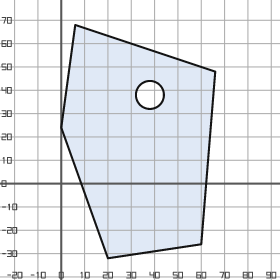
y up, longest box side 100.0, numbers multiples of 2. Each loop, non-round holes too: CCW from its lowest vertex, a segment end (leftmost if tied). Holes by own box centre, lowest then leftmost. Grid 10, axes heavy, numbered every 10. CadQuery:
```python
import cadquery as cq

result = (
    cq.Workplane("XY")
    .moveTo(20.0, -32.0)
    .lineTo(60.0, -26.0)
    .lineTo(66.0, 48.0)
    .lineTo(6.0, 68.0)
    .lineTo(0.0, 24.0)
    .close()
    .moveTo(38.0, 38.0)
    .circle(6.0)
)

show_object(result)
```